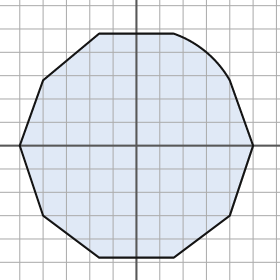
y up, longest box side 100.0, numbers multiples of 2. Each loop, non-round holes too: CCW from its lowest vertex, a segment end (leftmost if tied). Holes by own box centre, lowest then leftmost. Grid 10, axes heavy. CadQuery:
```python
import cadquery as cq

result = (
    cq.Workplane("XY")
    .moveTo(-16.0, -48.0)
    .lineTo(16.0, -48.0)
    .lineTo(40.0, -30.0)
    .lineTo(50.0, 0.0)
    .lineTo(40.0, 28.0)
    .threePointArc((30.0, 40.0), (16.0, 48.0))
    .lineTo(-16.0, 48.0)
    .lineTo(-40.0, 28.0)
    .lineTo(-50.0, 0.0)
    .lineTo(-40.0, -30.0)
    .close()
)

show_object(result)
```